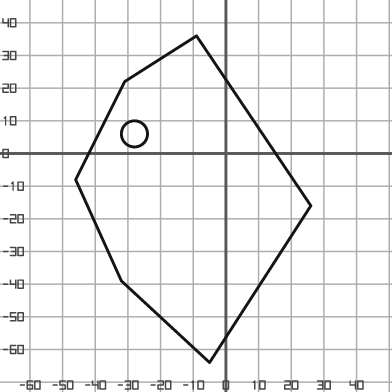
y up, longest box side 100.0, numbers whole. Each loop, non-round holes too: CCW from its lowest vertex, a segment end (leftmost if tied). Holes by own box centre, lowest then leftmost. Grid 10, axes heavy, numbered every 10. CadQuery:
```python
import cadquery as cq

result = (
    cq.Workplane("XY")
    .moveTo(-5.0, -64.0)
    .lineTo(26.0, -16.0)
    .lineTo(-9.0, 36.0)
    .lineTo(-31.0, 22.0)
    .lineTo(-46.0, -8.0)
    .lineTo(-32.0, -39.0)
    .close()
    .moveTo(-28.0, 6.0)
    .circle(4.0)
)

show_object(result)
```